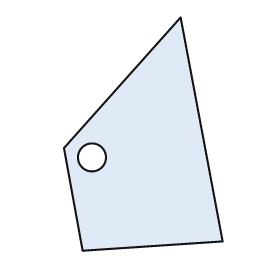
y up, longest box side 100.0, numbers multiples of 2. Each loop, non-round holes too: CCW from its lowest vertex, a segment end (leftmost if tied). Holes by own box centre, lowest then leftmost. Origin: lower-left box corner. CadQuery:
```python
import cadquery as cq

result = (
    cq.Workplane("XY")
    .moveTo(8.0, 0.0)
    .lineTo(68.0, 4.0)
    .lineTo(50.0, 100.0)
    .lineTo(0.0, 44.0)
    .close()
    .moveTo(12.0, 40.0)
    .circle(6.0)
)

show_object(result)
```